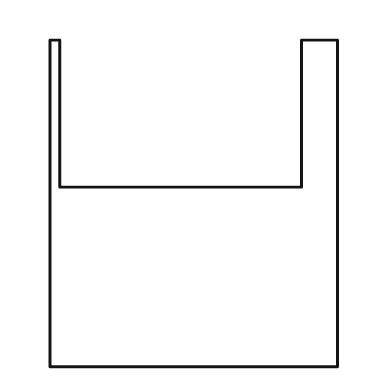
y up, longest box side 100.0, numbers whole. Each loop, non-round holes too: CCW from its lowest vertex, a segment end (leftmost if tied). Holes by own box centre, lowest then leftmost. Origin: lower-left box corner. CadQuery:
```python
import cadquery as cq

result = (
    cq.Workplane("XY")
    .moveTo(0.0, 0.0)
    .lineTo(88.0, 0.0)
    .lineTo(88.0, 100.0)
    .lineTo(77.0, 100.0)
    .lineTo(77.0, 55.0)
    .lineTo(3.0, 55.0)
    .lineTo(3.0, 100.0)
    .lineTo(0.0, 100.0)
    .close()
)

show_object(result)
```